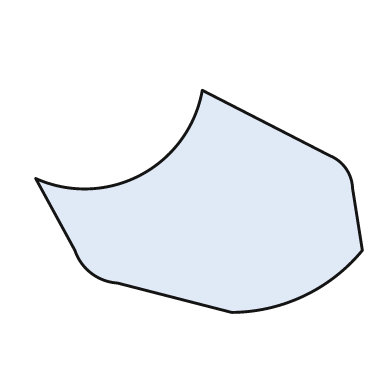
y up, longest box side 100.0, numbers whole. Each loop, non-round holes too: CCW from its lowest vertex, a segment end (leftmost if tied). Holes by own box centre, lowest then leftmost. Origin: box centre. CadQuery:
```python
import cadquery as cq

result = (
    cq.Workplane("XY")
    .moveTo(10.0, -34.0)
    .threePointArc((32.0, -29.0), (50.0, -15.0))
    .lineTo(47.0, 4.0)
    .threePointArc((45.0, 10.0), (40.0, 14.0))
    .lineTo(1.0, 34.0)
    .threePointArc((-18.0, 8.0), (-50.0, 7.0))
    .lineTo(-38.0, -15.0)
    .threePointArc((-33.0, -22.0), (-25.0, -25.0))
    .close()
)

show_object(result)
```